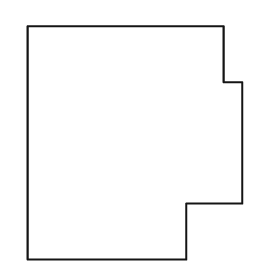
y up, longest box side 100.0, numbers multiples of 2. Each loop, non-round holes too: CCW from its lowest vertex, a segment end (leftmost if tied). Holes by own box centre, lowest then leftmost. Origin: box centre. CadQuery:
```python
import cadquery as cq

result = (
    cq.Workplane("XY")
    .moveTo(-46.0, -50.0)
    .lineTo(22.0, -50.0)
    .lineTo(22.0, -26.0)
    .lineTo(46.0, -26.0)
    .lineTo(46.0, 26.0)
    .lineTo(38.0, 26.0)
    .lineTo(38.0, 50.0)
    .lineTo(-46.0, 50.0)
    .close()
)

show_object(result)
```